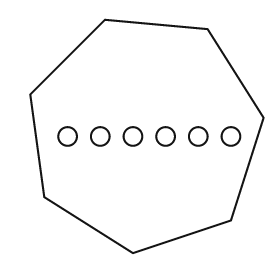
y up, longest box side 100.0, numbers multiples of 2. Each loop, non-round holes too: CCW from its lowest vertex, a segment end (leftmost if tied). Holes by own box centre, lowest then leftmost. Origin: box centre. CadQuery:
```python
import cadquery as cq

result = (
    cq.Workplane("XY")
    .moveTo(-6.0, -50.0)
    .lineTo(36.0, -36.0)
    .lineTo(50.0, 8.0)
    .lineTo(26.0, 46.0)
    .lineTo(-18.0, 50.0)
    .lineTo(-50.0, 18.0)
    .lineTo(-44.0, -26.0)
    .close()
    .moveTo(-34.0, 0.0)
    .circle(4.0)
    .moveTo(-20.0, 0.0)
    .circle(4.0)
    .moveTo(-6.0, 0.0)
    .circle(4.0)
    .moveTo(8.0, 0.0)
    .circle(4.0)
    .moveTo(22.0, 0.0)
    .circle(4.0)
    .moveTo(36.0, 0.0)
    .circle(4.0)
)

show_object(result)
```